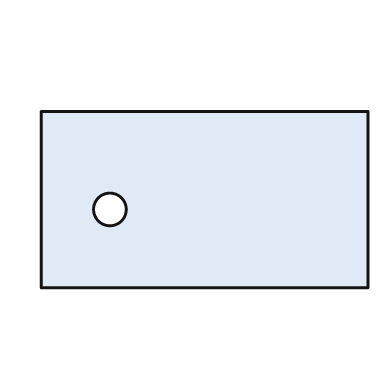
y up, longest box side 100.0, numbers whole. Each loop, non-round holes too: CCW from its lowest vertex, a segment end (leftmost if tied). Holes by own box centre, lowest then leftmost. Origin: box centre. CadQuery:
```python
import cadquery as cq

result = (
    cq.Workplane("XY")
    .moveTo(-50.0, -27.0)
    .lineTo(50.0, -27.0)
    .lineTo(50.0, 27.0)
    .lineTo(-50.0, 27.0)
    .close()
    .moveTo(-29.0, -3.0)
    .circle(5.0)
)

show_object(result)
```